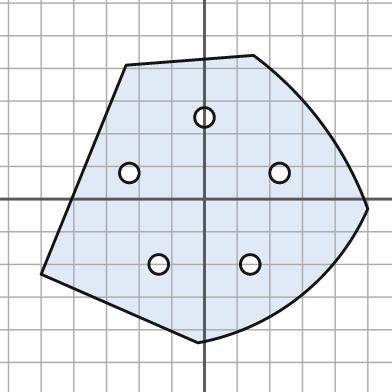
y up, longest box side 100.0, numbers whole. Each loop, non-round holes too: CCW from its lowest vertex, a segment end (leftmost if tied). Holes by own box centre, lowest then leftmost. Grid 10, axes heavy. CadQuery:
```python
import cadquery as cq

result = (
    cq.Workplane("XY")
    .moveTo(-2.0, -44.0)
    .threePointArc((29.0, -30.0), (50.0, -3.0))
    .threePointArc((36.0, 23.0), (15.0, 44.0))
    .lineTo(-24.0, 41.0)
    .lineTo(-50.0, -23.0)
    .close()
    .moveTo(-14.0, -20.0)
    .circle(3.0)
    .moveTo(14.0, -20.0)
    .circle(3.0)
    .moveTo(-23.0, 8.0)
    .circle(3.0)
    .moveTo(23.0, 8.0)
    .circle(3.0)
    .moveTo(0.0, 25.0)
    .circle(3.0)
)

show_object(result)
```